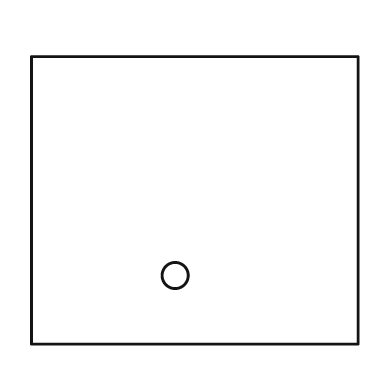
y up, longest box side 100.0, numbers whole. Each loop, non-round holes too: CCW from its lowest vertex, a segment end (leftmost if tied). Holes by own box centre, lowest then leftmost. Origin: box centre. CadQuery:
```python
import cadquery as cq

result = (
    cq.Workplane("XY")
    .moveTo(-50.0, -44.0)
    .lineTo(50.0, -44.0)
    .lineTo(50.0, 44.0)
    .lineTo(-50.0, 44.0)
    .close()
    .moveTo(-6.0, -23.0)
    .circle(4.0)
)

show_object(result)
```